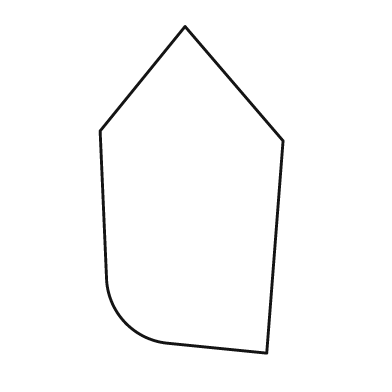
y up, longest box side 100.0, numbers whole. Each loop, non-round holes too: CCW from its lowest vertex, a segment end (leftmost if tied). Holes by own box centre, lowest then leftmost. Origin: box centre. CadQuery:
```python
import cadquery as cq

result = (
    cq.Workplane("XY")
    .moveTo(23.0, -50.0)
    .lineTo(28.0, 15.0)
    .lineTo(-2.0, 50.0)
    .lineTo(-28.0, 18.0)
    .lineTo(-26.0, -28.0)
    .threePointArc((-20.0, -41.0), (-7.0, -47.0))
    .close()
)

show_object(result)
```